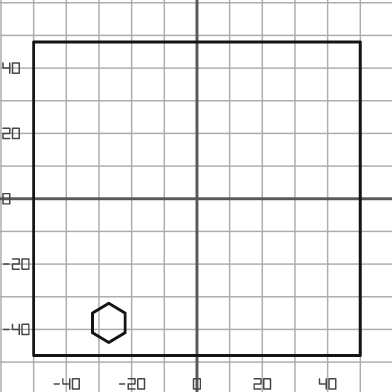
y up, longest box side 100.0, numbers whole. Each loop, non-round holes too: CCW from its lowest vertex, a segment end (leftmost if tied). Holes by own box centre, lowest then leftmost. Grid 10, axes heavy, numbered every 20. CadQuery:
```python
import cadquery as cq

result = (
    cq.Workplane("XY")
    .moveTo(-50.0, -48.0)
    .lineTo(50.0, -48.0)
    .lineTo(50.0, 48.0)
    .lineTo(-50.0, 48.0)
    .close()
    .moveTo(-27.0, -44.0)
    .lineTo(-22.0, -41.0)
    .lineTo(-22.0, -35.0)
    .lineTo(-27.0, -32.0)
    .lineTo(-32.0, -35.0)
    .lineTo(-32.0, -41.0)
    .close()
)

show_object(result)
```